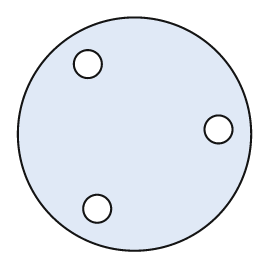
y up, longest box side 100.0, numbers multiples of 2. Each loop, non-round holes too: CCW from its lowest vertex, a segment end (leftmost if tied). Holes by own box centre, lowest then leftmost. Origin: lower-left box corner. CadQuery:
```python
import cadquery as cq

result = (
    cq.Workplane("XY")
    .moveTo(50.0, 50.0)
    .circle(50.0)
    .moveTo(34.0, 18.0)
    .circle(6.0)
    .moveTo(86.0, 52.0)
    .circle(6.0)
    .moveTo(30.0, 80.0)
    .circle(6.0)
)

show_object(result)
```